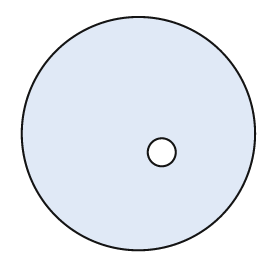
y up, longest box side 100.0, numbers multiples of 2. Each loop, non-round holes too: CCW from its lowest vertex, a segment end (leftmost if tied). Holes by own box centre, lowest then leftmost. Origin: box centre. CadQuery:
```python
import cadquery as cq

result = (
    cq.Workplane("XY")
    .moveTo(0.0, 0.0)
    .circle(50.0)
    .moveTo(10.0, -8.0)
    .circle(6.0)
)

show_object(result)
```